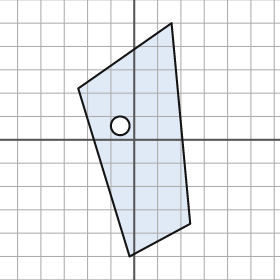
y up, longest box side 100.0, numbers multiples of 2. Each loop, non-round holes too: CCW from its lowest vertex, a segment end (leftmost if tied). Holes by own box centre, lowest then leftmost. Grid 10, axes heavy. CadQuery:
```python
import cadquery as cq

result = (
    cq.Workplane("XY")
    .moveTo(-2.0, -50.0)
    .lineTo(24.0, -36.0)
    .lineTo(16.0, 50.0)
    .lineTo(-24.0, 22.0)
    .close()
    .moveTo(-6.0, 6.0)
    .circle(4.0)
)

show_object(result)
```